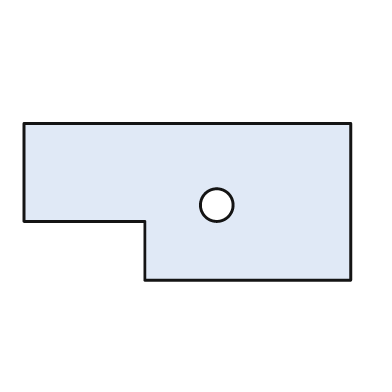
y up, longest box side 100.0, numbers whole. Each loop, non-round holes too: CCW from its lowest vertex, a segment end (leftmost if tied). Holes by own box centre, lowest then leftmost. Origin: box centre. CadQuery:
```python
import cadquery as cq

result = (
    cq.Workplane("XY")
    .moveTo(-13.0, -24.0)
    .lineTo(50.0, -24.0)
    .lineTo(50.0, 24.0)
    .lineTo(-50.0, 24.0)
    .lineTo(-50.0, -6.0)
    .lineTo(-13.0, -6.0)
    .close()
    .moveTo(9.0, -1.0)
    .circle(5.0)
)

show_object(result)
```